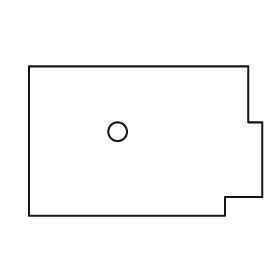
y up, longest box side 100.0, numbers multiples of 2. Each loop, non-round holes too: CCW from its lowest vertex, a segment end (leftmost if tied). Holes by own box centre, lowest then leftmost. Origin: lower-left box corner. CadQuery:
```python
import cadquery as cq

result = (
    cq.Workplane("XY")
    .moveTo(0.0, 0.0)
    .lineTo(84.0, 0.0)
    .lineTo(84.0, 8.0)
    .lineTo(100.0, 8.0)
    .lineTo(100.0, 40.0)
    .lineTo(94.0, 40.0)
    .lineTo(94.0, 64.0)
    .lineTo(0.0, 64.0)
    .close()
    .moveTo(38.0, 36.0)
    .circle(4.0)
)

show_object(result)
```